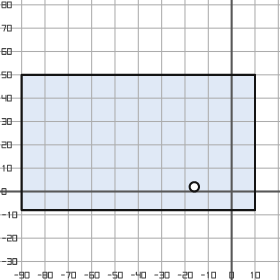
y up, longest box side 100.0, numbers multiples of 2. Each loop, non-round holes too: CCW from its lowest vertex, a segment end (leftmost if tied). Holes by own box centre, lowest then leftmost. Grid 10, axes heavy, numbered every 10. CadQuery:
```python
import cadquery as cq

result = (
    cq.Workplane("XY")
    .moveTo(-90.0, -8.0)
    .lineTo(10.0, -8.0)
    .lineTo(10.0, 50.0)
    .lineTo(-90.0, 50.0)
    .close()
    .moveTo(-16.0, 2.0)
    .circle(2.0)
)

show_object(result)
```